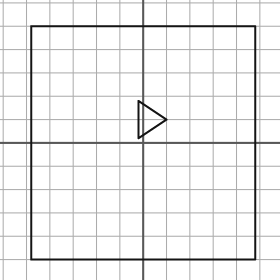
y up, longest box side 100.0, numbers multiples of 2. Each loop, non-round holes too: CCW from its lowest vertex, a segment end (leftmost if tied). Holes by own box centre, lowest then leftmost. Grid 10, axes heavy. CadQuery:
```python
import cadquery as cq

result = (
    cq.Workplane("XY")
    .moveTo(-48.0, -50.0)
    .lineTo(48.0, -50.0)
    .lineTo(48.0, 50.0)
    .lineTo(-48.0, 50.0)
    .close()
    .moveTo(-2.0, 2.0)
    .lineTo(10.0, 10.0)
    .lineTo(-2.0, 18.0)
    .close()
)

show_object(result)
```